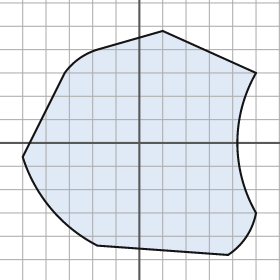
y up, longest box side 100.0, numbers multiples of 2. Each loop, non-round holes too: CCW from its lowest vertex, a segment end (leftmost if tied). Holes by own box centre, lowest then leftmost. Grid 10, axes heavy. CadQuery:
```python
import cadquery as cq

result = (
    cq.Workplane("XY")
    .moveTo(38.0, -48.0)
    .threePointArc((46.0, -40.0), (50.0, -30.0))
    .threePointArc((42.0, 0.0), (50.0, 30.0))
    .lineTo(10.0, 48.0)
    .lineTo(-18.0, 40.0)
    .threePointArc((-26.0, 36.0), (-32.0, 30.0))
    .lineTo(-50.0, -6.0)
    .threePointArc((-38.0, -28.0), (-18.0, -44.0))
    .close()
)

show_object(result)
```